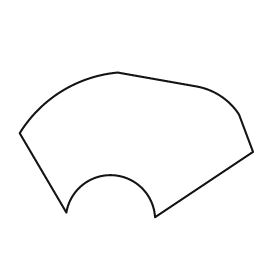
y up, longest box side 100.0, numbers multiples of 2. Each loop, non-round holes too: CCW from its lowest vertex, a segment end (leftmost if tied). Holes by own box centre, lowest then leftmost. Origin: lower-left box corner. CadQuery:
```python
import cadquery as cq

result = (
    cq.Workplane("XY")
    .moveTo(58.0, 0.0)
    .lineTo(100.0, 28.0)
    .lineTo(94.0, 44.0)
    .threePointArc((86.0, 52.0), (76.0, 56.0))
    .lineTo(42.0, 62.0)
    .threePointArc((18.0, 54.0), (0.0, 36.0))
    .lineTo(20.0, 2.0)
    .threePointArc((40.0, 18.0), (58.0, 0.0))
    .close()
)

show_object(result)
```